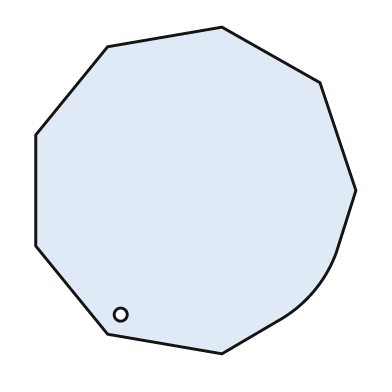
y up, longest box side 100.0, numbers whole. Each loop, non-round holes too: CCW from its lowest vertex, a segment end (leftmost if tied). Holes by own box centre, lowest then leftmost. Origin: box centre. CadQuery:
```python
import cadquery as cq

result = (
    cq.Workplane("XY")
    .moveTo(8.0, -50.0)
    .lineTo(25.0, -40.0)
    .threePointArc((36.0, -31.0), (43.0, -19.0))
    .lineTo(49.0, 0.0)
    .lineTo(38.0, 33.0)
    .lineTo(8.0, 50.0)
    .lineTo(-27.0, 44.0)
    .lineTo(-49.0, 17.0)
    .lineTo(-49.0, -17.0)
    .lineTo(-27.0, -44.0)
    .close()
    .moveTo(-23.0, -38.0)
    .circle(2.0)
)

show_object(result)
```